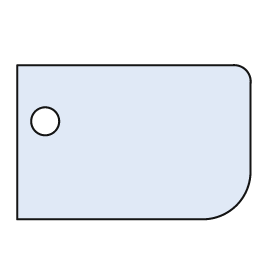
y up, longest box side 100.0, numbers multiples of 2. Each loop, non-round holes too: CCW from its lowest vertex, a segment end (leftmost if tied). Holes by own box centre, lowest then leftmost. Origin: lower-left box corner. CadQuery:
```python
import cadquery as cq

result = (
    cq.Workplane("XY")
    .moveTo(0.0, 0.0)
    .lineTo(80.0, 0.0)
    .threePointArc((94.0, 6.0), (100.0, 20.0))
    .lineTo(100.0, 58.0)
    .threePointArc((98.0, 64.0), (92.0, 66.0))
    .lineTo(0.0, 66.0)
    .close()
    .moveTo(12.0, 42.0)
    .circle(6.0)
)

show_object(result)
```